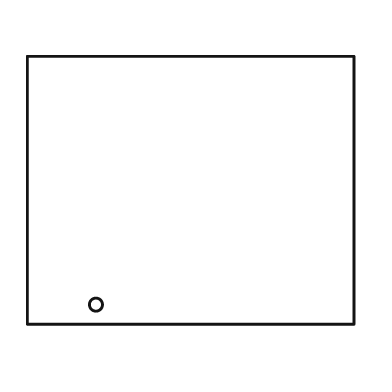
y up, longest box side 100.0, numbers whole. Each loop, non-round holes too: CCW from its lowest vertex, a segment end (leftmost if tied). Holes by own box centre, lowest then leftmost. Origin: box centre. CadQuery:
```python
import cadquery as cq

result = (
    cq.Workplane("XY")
    .moveTo(-50.0, -41.0)
    .lineTo(50.0, -41.0)
    .lineTo(50.0, 41.0)
    .lineTo(-50.0, 41.0)
    .close()
    .moveTo(-29.0, -35.0)
    .circle(2.0)
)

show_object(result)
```